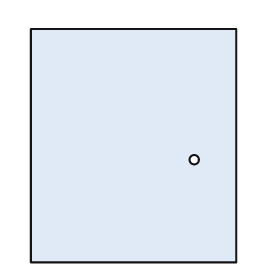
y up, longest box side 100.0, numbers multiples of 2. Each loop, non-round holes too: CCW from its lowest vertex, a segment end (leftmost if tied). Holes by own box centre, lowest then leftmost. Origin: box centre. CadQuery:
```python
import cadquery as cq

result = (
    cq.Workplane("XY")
    .moveTo(-44.0, -50.0)
    .lineTo(44.0, -50.0)
    .lineTo(44.0, 50.0)
    .lineTo(-44.0, 50.0)
    .close()
    .moveTo(26.0, -6.0)
    .circle(2.0)
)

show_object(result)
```